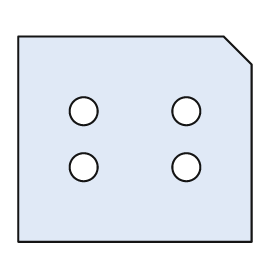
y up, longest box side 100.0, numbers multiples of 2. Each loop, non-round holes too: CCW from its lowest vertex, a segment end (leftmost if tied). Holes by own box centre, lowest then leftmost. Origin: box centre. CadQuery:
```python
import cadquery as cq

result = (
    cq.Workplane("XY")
    .moveTo(-50.0, -44.0)
    .lineTo(50.0, -44.0)
    .lineTo(50.0, 32.0)
    .lineTo(38.0, 44.0)
    .lineTo(-50.0, 44.0)
    .close()
    .moveTo(-22.0, -12.0)
    .circle(6.0)
    .moveTo(22.0, -12.0)
    .circle(6.0)
    .moveTo(-22.0, 12.0)
    .circle(6.0)
    .moveTo(22.0, 12.0)
    .circle(6.0)
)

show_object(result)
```